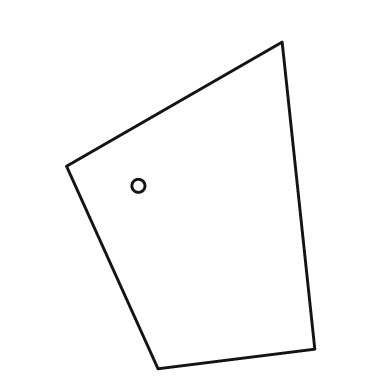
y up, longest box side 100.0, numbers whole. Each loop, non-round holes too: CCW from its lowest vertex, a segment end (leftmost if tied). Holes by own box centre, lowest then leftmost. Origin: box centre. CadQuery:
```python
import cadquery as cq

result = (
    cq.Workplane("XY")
    .moveTo(-10.0, -50.0)
    .lineTo(38.0, -44.0)
    .lineTo(28.0, 50.0)
    .lineTo(-38.0, 12.0)
    .close()
    .moveTo(-16.0, 6.0)
    .circle(2.0)
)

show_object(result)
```